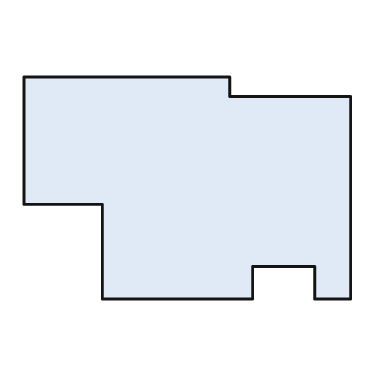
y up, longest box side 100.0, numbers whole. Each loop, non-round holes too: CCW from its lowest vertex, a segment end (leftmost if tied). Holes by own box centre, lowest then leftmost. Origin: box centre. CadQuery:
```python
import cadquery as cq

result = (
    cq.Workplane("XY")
    .moveTo(-26.0, -34.0)
    .lineTo(20.0, -34.0)
    .lineTo(20.0, -24.0)
    .lineTo(39.0, -24.0)
    .lineTo(39.0, -34.0)
    .lineTo(50.0, -34.0)
    .lineTo(50.0, 28.0)
    .lineTo(13.0, 28.0)
    .lineTo(13.0, 34.0)
    .lineTo(-50.0, 34.0)
    .lineTo(-50.0, -5.0)
    .lineTo(-26.0, -5.0)
    .close()
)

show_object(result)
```